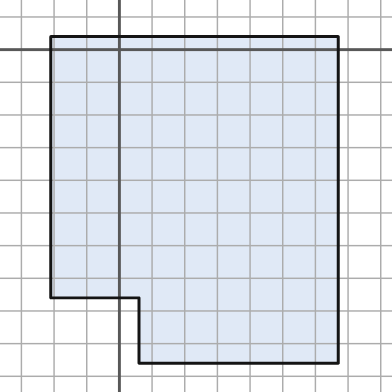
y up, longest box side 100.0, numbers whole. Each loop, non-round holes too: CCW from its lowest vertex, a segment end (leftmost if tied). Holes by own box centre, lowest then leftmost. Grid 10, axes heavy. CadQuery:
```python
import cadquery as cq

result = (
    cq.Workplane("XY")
    .moveTo(6.0, -96.0)
    .lineTo(67.0, -96.0)
    .lineTo(67.0, 4.0)
    .lineTo(-21.0, 4.0)
    .lineTo(-21.0, -76.0)
    .lineTo(6.0, -76.0)
    .close()
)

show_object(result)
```